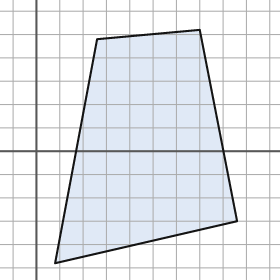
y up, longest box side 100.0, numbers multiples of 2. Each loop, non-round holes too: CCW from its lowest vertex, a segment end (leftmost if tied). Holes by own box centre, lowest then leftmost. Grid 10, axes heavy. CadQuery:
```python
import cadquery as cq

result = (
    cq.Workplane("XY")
    .moveTo(8.0, -48.0)
    .lineTo(86.0, -30.0)
    .lineTo(70.0, 52.0)
    .lineTo(26.0, 48.0)
    .close()
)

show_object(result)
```